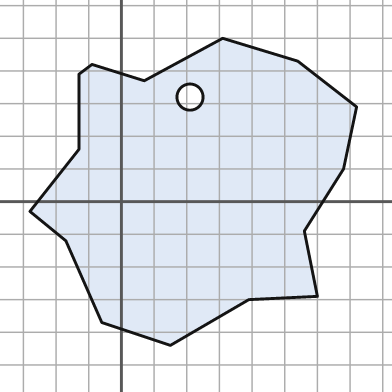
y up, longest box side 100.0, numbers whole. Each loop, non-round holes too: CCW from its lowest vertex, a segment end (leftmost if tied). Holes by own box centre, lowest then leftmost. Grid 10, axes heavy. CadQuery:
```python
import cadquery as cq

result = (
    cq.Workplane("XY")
    .moveTo(15.0, -44.0)
    .lineTo(39.0, -30.0)
    .lineTo(60.0, -29.0)
    .lineTo(56.0, -9.0)
    .lineTo(68.0, 10.0)
    .lineTo(72.0, 29.0)
    .lineTo(54.0, 43.0)
    .lineTo(31.0, 50.0)
    .lineTo(7.0, 37.0)
    .lineTo(-9.0, 42.0)
    .lineTo(-13.0, 39.0)
    .lineTo(-13.0, 16.0)
    .lineTo(-28.0, -3.0)
    .lineTo(-17.0, -12.0)
    .lineTo(-6.0, -37.0)
    .close()
    .moveTo(21.0, 32.0)
    .circle(4.0)
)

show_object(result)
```